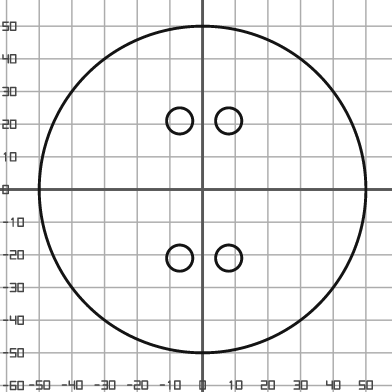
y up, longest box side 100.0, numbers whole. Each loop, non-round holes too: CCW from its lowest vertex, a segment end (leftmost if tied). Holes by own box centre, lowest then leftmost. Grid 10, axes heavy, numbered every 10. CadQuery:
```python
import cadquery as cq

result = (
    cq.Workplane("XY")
    .moveTo(0.0, 0.0)
    .circle(50.0)
    .moveTo(-7.0, -21.0)
    .circle(4.0)
    .moveTo(8.0, -21.0)
    .circle(4.0)
    .moveTo(-7.0, 21.0)
    .circle(4.0)
    .moveTo(8.0, 21.0)
    .circle(4.0)
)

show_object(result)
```